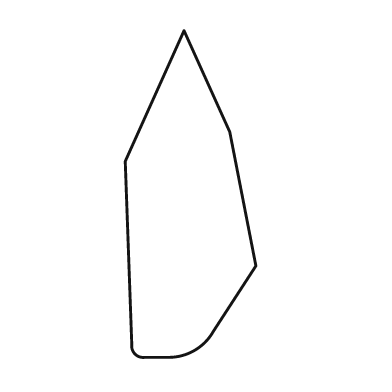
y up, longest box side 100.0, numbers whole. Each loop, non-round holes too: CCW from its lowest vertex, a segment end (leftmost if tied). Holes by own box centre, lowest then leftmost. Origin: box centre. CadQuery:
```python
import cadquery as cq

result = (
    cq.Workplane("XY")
    .moveTo(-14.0, -50.0)
    .lineTo(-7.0, -50.0)
    .threePointArc((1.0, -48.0), (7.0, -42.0))
    .lineTo(20.0, -22.0)
    .lineTo(12.0, 19.0)
    .lineTo(-2.0, 50.0)
    .lineTo(-20.0, 10.0)
    .lineTo(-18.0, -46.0)
    .threePointArc((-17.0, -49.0), (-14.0, -50.0))
    .close()
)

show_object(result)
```